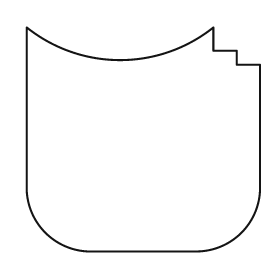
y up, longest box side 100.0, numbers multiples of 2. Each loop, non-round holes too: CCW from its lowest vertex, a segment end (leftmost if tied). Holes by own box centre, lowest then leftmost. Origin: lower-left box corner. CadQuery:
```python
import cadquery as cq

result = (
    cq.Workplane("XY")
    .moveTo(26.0, 0.0)
    .lineTo(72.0, 0.0)
    .threePointArc((92.0, 8.0), (100.0, 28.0))
    .lineTo(100.0, 80.0)
    .lineTo(90.0, 80.0)
    .lineTo(90.0, 86.0)
    .lineTo(80.0, 86.0)
    .lineTo(80.0, 96.0)
    .threePointArc((40.0, 82.0), (0.0, 96.0))
    .lineTo(0.0, 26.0)
    .threePointArc((8.0, 8.0), (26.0, 0.0))
    .close()
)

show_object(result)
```